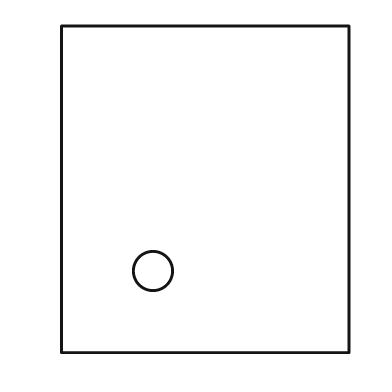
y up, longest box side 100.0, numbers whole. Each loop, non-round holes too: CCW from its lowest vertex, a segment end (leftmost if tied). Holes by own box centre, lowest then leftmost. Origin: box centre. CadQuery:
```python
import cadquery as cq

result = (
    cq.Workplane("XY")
    .moveTo(-44.0, -50.0)
    .lineTo(44.0, -50.0)
    .lineTo(44.0, 50.0)
    .lineTo(-44.0, 50.0)
    .close()
    .moveTo(-16.0, -25.0)
    .circle(6.0)
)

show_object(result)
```